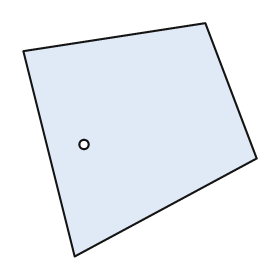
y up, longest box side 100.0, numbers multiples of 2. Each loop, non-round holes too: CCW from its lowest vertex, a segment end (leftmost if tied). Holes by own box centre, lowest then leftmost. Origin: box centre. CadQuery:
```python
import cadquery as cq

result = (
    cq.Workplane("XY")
    .moveTo(-28.0, -50.0)
    .lineTo(50.0, -8.0)
    .lineTo(28.0, 50.0)
    .lineTo(-50.0, 38.0)
    .close()
    .moveTo(-24.0, -2.0)
    .circle(2.0)
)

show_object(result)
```